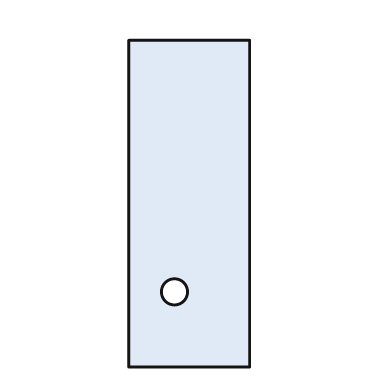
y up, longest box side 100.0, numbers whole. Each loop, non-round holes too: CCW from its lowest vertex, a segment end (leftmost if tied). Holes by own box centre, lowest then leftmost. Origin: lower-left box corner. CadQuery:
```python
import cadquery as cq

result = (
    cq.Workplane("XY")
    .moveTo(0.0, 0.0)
    .lineTo(37.0, 0.0)
    .lineTo(37.0, 100.0)
    .lineTo(0.0, 100.0)
    .close()
    .moveTo(14.0, 23.0)
    .circle(4.0)
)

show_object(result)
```